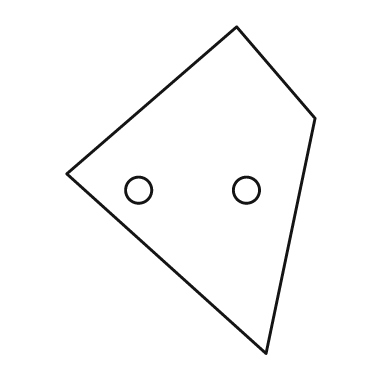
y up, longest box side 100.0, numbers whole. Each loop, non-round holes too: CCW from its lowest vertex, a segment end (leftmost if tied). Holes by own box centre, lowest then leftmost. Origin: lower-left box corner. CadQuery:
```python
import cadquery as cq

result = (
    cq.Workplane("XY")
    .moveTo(61.0, 0.0)
    .lineTo(76.0, 72.0)
    .lineTo(52.0, 100.0)
    .lineTo(0.0, 55.0)
    .close()
    .moveTo(22.0, 50.0)
    .circle(4.0)
    .moveTo(55.0, 50.0)
    .circle(4.0)
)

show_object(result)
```